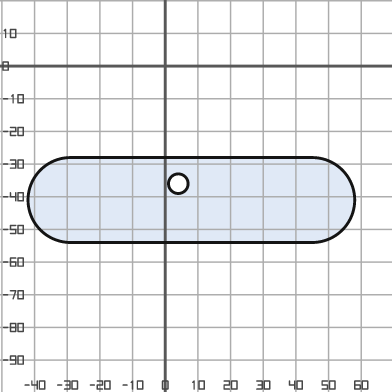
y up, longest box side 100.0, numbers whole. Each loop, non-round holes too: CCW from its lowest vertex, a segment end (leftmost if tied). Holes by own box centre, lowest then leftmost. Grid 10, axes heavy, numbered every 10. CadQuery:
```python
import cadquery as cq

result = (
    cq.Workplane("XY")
    .moveTo(-29.0, -54.0)
    .lineTo(45.0, -54.0)
    .threePointArc((58.0, -41.0), (45.0, -28.0))
    .lineTo(-29.0, -28.0)
    .threePointArc((-42.0, -41.0), (-29.0, -54.0))
    .close()
    .moveTo(4.0, -36.0)
    .circle(3.0)
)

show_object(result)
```